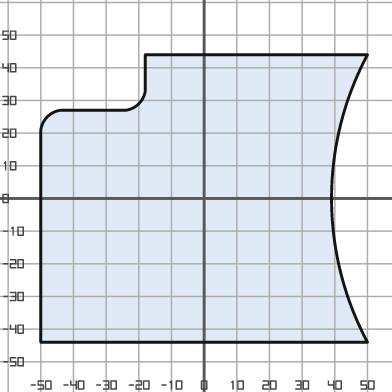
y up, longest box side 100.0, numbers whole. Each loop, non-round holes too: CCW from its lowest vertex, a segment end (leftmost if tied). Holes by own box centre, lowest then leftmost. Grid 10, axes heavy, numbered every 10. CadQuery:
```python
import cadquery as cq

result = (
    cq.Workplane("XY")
    .moveTo(-50.0, -44.0)
    .lineTo(50.0, -44.0)
    .threePointArc((39.0, 0.0), (50.0, 44.0))
    .lineTo(-18.0, 44.0)
    .lineTo(-18.0, 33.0)
    .threePointArc((-20.0, 29.0), (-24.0, 27.0))
    .lineTo(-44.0, 27.0)
    .threePointArc((-48.0, 25.0), (-50.0, 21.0))
    .close()
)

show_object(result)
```